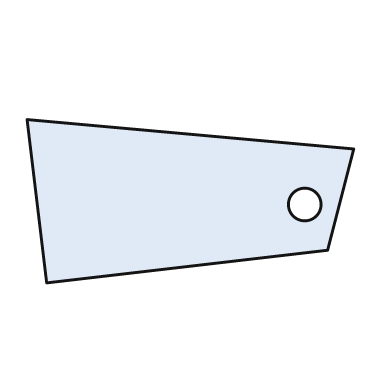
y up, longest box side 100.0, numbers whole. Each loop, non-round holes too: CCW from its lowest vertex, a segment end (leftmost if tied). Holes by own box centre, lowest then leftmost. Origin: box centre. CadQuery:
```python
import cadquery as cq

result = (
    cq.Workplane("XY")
    .moveTo(-44.0, -25.0)
    .lineTo(42.0, -15.0)
    .lineTo(50.0, 16.0)
    .lineTo(-50.0, 25.0)
    .close()
    .moveTo(35.0, -1.0)
    .circle(5.0)
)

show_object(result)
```